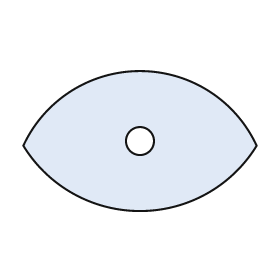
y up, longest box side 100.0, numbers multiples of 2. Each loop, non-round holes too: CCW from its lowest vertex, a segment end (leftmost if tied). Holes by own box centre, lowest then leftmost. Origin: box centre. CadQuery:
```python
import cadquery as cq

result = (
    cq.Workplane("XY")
    .moveTo(-50.0, -2.0)
    .threePointArc((0.0, -30.0), (50.0, -2.0))
    .threePointArc((0.0, 30.0), (-50.0, -2.0))
    .close()
    .moveTo(0.0, 0.0)
    .circle(6.0)
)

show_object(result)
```